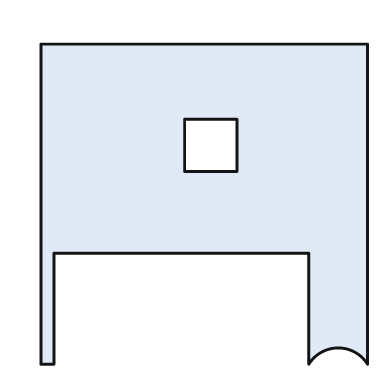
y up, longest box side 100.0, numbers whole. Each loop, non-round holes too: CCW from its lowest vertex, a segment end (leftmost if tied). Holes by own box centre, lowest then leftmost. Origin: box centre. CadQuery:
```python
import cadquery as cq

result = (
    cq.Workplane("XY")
    .moveTo(-50.0, -49.0)
    .lineTo(-46.0, -49.0)
    .lineTo(-46.0, -15.0)
    .lineTo(32.0, -15.0)
    .lineTo(32.0, -49.0)
    .threePointArc((41.0, -44.0), (50.0, -49.0))
    .lineTo(50.0, 49.0)
    .lineTo(-50.0, 49.0)
    .close()
    .moveTo(-6.0, 10.0)
    .lineTo(10.0, 10.0)
    .lineTo(10.0, 26.0)
    .lineTo(-6.0, 26.0)
    .close()
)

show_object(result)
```